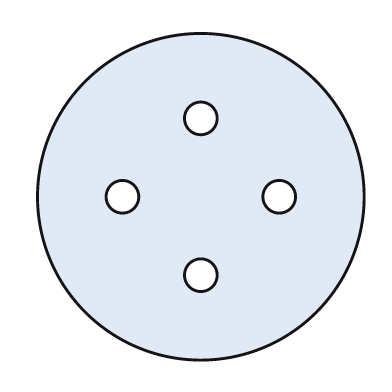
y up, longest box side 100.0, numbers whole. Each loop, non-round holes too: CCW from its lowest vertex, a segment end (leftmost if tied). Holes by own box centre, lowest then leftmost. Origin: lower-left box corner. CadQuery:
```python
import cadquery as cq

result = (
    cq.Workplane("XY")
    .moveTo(50.0, 50.0)
    .circle(50.0)
    .moveTo(50.0, 26.0)
    .circle(5.0)
    .moveTo(26.0, 50.0)
    .circle(5.0)
    .moveTo(74.0, 50.0)
    .circle(5.0)
    .moveTo(50.0, 74.0)
    .circle(5.0)
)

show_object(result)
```